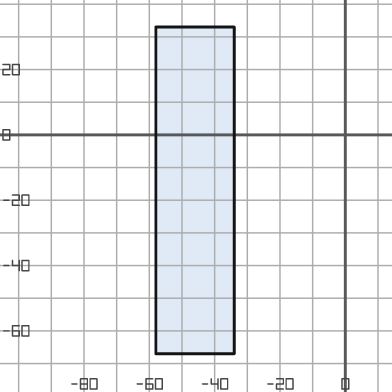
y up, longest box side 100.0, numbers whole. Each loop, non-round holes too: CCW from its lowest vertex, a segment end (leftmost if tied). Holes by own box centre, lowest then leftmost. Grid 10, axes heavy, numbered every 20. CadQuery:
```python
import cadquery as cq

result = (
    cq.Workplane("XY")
    .moveTo(-58.0, -67.0)
    .lineTo(-34.0, -67.0)
    .lineTo(-34.0, 33.0)
    .lineTo(-58.0, 33.0)
    .close()
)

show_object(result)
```